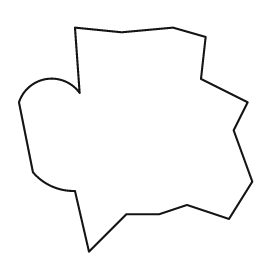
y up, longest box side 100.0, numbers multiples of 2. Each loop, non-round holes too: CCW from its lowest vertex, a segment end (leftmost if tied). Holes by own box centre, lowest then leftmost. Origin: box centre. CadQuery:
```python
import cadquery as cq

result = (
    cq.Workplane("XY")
    .moveTo(-20.0, -48.0)
    .lineTo(-4.0, -32.0)
    .lineTo(10.0, -32.0)
    .lineTo(22.0, -28.0)
    .lineTo(40.0, -34.0)
    .lineTo(50.0, -18.0)
    .lineTo(42.0, 4.0)
    .lineTo(48.0, 16.0)
    .lineTo(28.0, 26.0)
    .lineTo(30.0, 44.0)
    .lineTo(16.0, 48.0)
    .lineTo(-6.0, 46.0)
    .lineTo(-26.0, 48.0)
    .lineTo(-24.0, 20.0)
    .threePointArc((-38.0, 26.0), (-50.0, 16.0))
    .lineTo(-44.0, -14.0)
    .threePointArc((-36.0, -20.0), (-26.0, -22.0))
    .close()
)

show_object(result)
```